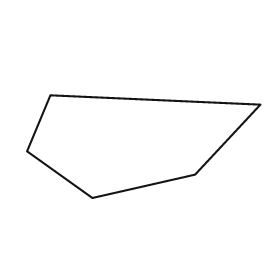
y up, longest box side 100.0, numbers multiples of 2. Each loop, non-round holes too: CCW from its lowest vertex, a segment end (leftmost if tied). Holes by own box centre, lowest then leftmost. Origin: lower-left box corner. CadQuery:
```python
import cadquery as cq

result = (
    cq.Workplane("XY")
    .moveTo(28.0, 0.0)
    .lineTo(72.0, 10.0)
    .lineTo(100.0, 40.0)
    .lineTo(10.0, 44.0)
    .lineTo(0.0, 20.0)
    .close()
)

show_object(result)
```